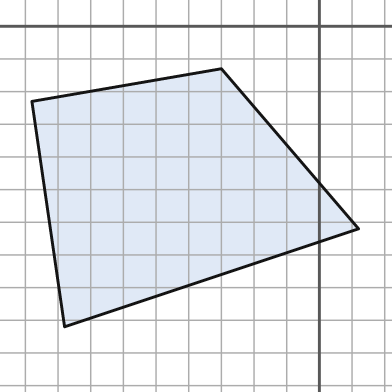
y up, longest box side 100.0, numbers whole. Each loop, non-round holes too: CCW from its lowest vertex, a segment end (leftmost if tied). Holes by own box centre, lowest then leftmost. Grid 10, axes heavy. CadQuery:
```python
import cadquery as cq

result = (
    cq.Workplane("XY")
    .moveTo(-78.0, -92.0)
    .lineTo(12.0, -62.0)
    .lineTo(-30.0, -13.0)
    .lineTo(-88.0, -23.0)
    .close()
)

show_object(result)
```